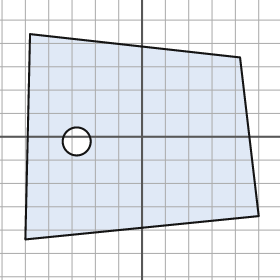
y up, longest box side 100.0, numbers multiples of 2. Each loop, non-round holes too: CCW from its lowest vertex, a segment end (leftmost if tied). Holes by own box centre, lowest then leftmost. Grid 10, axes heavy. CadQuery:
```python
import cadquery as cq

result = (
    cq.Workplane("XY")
    .moveTo(-50.0, -44.0)
    .lineTo(50.0, -34.0)
    .lineTo(42.0, 34.0)
    .lineTo(-48.0, 44.0)
    .close()
    .moveTo(-28.0, -2.0)
    .circle(6.0)
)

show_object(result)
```